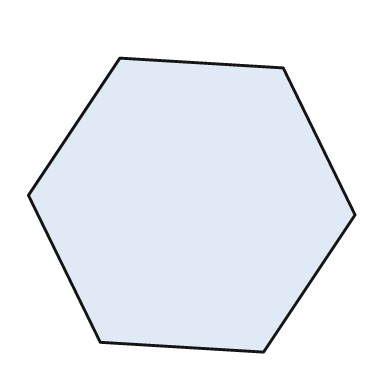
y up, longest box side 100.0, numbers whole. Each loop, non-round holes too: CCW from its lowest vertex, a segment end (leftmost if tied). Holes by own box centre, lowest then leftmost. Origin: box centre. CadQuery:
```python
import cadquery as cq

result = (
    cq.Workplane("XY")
    .moveTo(22.0, -45.0)
    .lineTo(50.0, -3.0)
    .lineTo(28.0, 42.0)
    .lineTo(-22.0, 45.0)
    .lineTo(-50.0, 3.0)
    .lineTo(-28.0, -42.0)
    .close()
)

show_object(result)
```